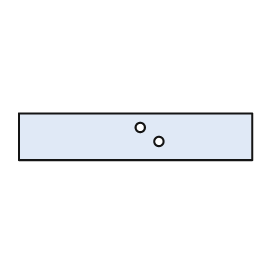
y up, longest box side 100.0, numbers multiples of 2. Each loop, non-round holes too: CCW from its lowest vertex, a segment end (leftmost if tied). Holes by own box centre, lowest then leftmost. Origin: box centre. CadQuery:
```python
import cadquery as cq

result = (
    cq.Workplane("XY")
    .moveTo(-50.0, -10.0)
    .lineTo(50.0, -10.0)
    .lineTo(50.0, 10.0)
    .lineTo(-50.0, 10.0)
    .close()
    .moveTo(10.0, -2.0)
    .circle(2.0)
    .moveTo(2.0, 4.0)
    .circle(2.0)
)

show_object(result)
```